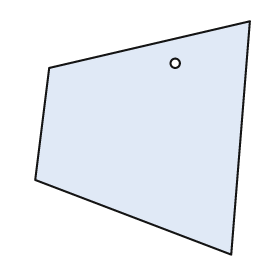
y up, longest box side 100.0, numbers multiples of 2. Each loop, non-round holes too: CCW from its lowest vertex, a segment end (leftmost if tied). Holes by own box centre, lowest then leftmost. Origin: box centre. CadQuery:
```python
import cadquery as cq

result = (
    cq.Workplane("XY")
    .moveTo(38.0, -50.0)
    .lineTo(46.0, 50.0)
    .lineTo(-40.0, 30.0)
    .lineTo(-46.0, -18.0)
    .close()
    .moveTo(14.0, 32.0)
    .circle(2.0)
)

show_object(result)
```